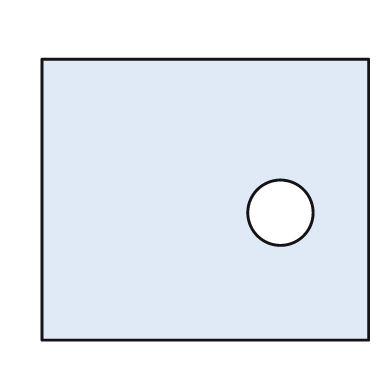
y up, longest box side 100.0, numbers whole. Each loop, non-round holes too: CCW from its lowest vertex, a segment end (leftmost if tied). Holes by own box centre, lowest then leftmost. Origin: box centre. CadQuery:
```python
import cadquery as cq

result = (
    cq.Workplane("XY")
    .moveTo(-50.0, -43.0)
    .lineTo(50.0, -43.0)
    .lineTo(50.0, 43.0)
    .lineTo(-50.0, 43.0)
    .close()
    .moveTo(23.0, -4.0)
    .circle(10.0)
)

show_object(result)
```